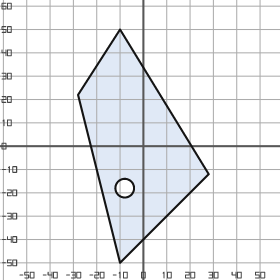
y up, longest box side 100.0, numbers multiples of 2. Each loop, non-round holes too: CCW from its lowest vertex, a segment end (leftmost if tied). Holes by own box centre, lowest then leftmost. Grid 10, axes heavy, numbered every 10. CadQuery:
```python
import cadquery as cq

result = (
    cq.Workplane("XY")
    .moveTo(-10.0, -50.0)
    .lineTo(28.0, -12.0)
    .lineTo(-10.0, 50.0)
    .lineTo(-28.0, 22.0)
    .close()
    .moveTo(-8.0, -18.0)
    .circle(4.0)
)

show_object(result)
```